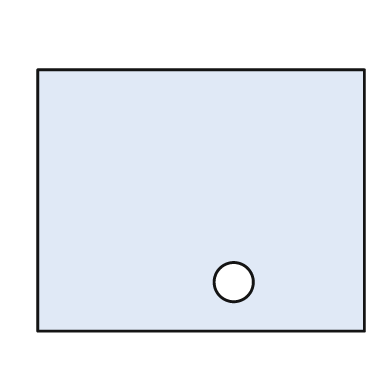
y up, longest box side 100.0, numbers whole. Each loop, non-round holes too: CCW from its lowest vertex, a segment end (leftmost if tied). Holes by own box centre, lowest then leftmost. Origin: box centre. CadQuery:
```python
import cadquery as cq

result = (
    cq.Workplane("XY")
    .moveTo(-50.0, -40.0)
    .lineTo(50.0, -40.0)
    .lineTo(50.0, 40.0)
    .lineTo(-50.0, 40.0)
    .close()
    .moveTo(10.0, -25.0)
    .circle(6.0)
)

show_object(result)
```